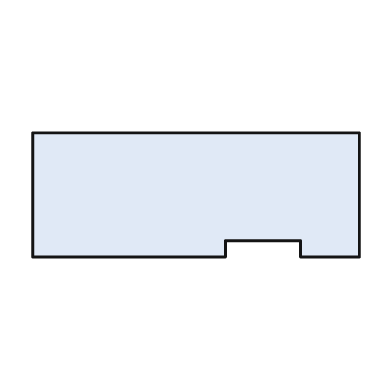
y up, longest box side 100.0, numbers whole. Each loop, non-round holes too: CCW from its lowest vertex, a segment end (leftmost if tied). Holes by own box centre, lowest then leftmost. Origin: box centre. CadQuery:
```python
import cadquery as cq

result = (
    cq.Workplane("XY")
    .moveTo(-50.0, -19.0)
    .lineTo(9.0, -19.0)
    .lineTo(9.0, -14.0)
    .lineTo(32.0, -14.0)
    .lineTo(32.0, -19.0)
    .lineTo(50.0, -19.0)
    .lineTo(50.0, 19.0)
    .lineTo(-50.0, 19.0)
    .close()
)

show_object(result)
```